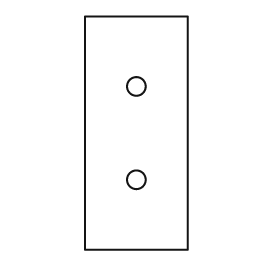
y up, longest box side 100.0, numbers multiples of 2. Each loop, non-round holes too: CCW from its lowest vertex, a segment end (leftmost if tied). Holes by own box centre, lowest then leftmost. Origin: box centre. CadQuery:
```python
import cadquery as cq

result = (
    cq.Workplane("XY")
    .moveTo(-22.0, -50.0)
    .lineTo(22.0, -50.0)
    .lineTo(22.0, 50.0)
    .lineTo(-22.0, 50.0)
    .close()
    .moveTo(0.0, -20.0)
    .circle(4.0)
    .moveTo(0.0, 20.0)
    .circle(4.0)
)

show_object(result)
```